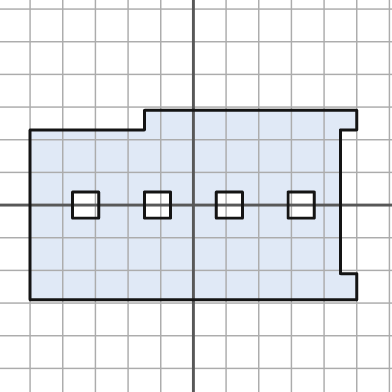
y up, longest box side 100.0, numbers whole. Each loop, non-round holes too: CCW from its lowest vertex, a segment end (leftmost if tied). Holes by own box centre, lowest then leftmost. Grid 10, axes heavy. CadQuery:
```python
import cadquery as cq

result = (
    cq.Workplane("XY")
    .moveTo(-50.0, -29.0)
    .lineTo(50.0, -29.0)
    .lineTo(50.0, -21.0)
    .lineTo(45.0, -21.0)
    .lineTo(45.0, 23.0)
    .lineTo(50.0, 23.0)
    .lineTo(50.0, 29.0)
    .lineTo(-15.0, 29.0)
    .lineTo(-15.0, 23.0)
    .lineTo(-50.0, 23.0)
    .close()
    .moveTo(-37.0, -4.0)
    .lineTo(-29.0, -4.0)
    .lineTo(-29.0, 4.0)
    .lineTo(-37.0, 4.0)
    .close()
    .moveTo(-15.0, -4.0)
    .lineTo(-7.0, -4.0)
    .lineTo(-7.0, 4.0)
    .lineTo(-15.0, 4.0)
    .close()
    .moveTo(7.0, -4.0)
    .lineTo(15.0, -4.0)
    .lineTo(15.0, 4.0)
    .lineTo(7.0, 4.0)
    .close()
    .moveTo(29.0, -4.0)
    .lineTo(37.0, -4.0)
    .lineTo(37.0, 4.0)
    .lineTo(29.0, 4.0)
    .close()
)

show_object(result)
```